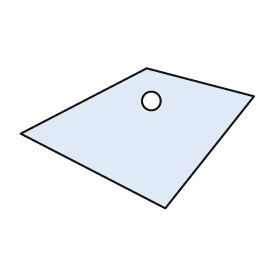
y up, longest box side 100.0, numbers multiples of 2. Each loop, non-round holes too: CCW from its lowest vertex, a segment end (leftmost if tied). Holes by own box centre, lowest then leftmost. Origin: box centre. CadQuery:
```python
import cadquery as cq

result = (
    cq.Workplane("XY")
    .moveTo(12.0, -30.0)
    .lineTo(50.0, 18.0)
    .lineTo(4.0, 30.0)
    .lineTo(-50.0, 2.0)
    .close()
    .moveTo(6.0, 16.0)
    .circle(4.0)
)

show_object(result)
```